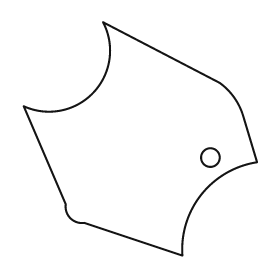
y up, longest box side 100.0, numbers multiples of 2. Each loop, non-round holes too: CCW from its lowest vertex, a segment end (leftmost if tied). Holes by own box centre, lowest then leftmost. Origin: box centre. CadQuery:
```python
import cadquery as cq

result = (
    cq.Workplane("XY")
    .moveTo(18.0, -50.0)
    .threePointArc((26.0, -24.0), (50.0, -10.0))
    .lineTo(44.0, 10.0)
    .threePointArc((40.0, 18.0), (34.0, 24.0))
    .lineTo(-16.0, 50.0)
    .threePointArc((-20.0, 20.0), (-50.0, 14.0))
    .lineTo(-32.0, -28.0)
    .threePointArc((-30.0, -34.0), (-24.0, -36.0))
    .close()
    .moveTo(30.0, -8.0)
    .circle(4.0)
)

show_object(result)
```